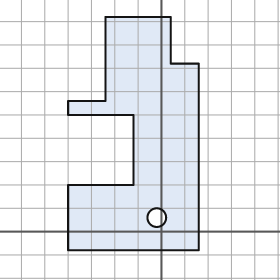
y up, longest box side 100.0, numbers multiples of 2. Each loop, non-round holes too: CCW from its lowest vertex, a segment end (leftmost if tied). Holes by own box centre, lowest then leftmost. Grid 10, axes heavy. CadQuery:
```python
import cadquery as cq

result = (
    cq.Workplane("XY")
    .moveTo(-40.0, -8.0)
    .lineTo(16.0, -8.0)
    .lineTo(16.0, 72.0)
    .lineTo(4.0, 72.0)
    .lineTo(4.0, 92.0)
    .lineTo(-24.0, 92.0)
    .lineTo(-24.0, 56.0)
    .lineTo(-40.0, 56.0)
    .lineTo(-40.0, 50.0)
    .lineTo(-12.0, 50.0)
    .lineTo(-12.0, 20.0)
    .lineTo(-40.0, 20.0)
    .close()
    .moveTo(-2.0, 6.0)
    .circle(4.0)
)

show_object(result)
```